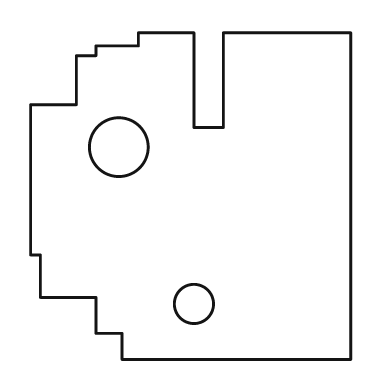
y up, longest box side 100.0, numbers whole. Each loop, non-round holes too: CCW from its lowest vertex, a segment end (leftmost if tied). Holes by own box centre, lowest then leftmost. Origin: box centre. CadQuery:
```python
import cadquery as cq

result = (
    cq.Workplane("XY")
    .moveTo(-21.0, -50.0)
    .lineTo(49.0, -50.0)
    .lineTo(49.0, 50.0)
    .lineTo(10.0, 50.0)
    .lineTo(10.0, 21.0)
    .lineTo(1.0, 21.0)
    .lineTo(1.0, 50.0)
    .lineTo(-16.0, 50.0)
    .lineTo(-16.0, 46.0)
    .lineTo(-29.0, 46.0)
    .lineTo(-29.0, 43.0)
    .lineTo(-35.0, 43.0)
    .lineTo(-35.0, 28.0)
    .lineTo(-49.0, 28.0)
    .lineTo(-49.0, -18.0)
    .lineTo(-46.0, -18.0)
    .lineTo(-46.0, -31.0)
    .lineTo(-29.0, -31.0)
    .lineTo(-29.0, -42.0)
    .lineTo(-21.0, -42.0)
    .close()
    .moveTo(1.0, -33.0)
    .circle(6.0)
    .moveTo(-22.0, 15.0)
    .circle(9.0)
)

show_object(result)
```